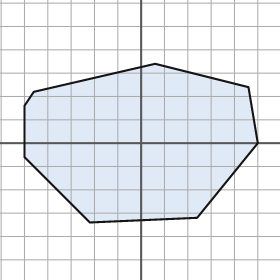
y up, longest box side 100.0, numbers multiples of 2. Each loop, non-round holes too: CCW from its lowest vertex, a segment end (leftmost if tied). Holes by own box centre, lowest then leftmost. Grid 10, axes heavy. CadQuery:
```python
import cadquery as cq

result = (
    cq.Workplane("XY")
    .moveTo(-22.0, -34.0)
    .lineTo(24.0, -32.0)
    .lineTo(50.0, 0.0)
    .lineTo(46.0, 24.0)
    .lineTo(6.0, 34.0)
    .lineTo(-46.0, 22.0)
    .lineTo(-50.0, 16.0)
    .lineTo(-50.0, -6.0)
    .close()
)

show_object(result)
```